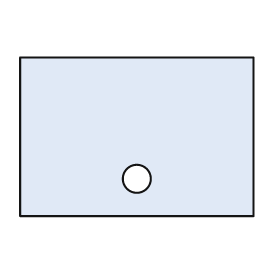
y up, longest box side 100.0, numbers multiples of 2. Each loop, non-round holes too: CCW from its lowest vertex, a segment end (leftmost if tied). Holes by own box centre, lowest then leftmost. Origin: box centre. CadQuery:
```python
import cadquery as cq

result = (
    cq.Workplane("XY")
    .moveTo(-50.0, -34.0)
    .lineTo(50.0, -34.0)
    .lineTo(50.0, 34.0)
    .lineTo(-50.0, 34.0)
    .close()
    .moveTo(0.0, -18.0)
    .circle(6.0)
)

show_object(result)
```